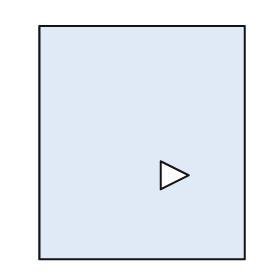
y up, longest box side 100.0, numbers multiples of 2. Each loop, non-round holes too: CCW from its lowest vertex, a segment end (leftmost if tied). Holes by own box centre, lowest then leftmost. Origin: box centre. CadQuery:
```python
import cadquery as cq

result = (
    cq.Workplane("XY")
    .moveTo(-44.0, -50.0)
    .lineTo(44.0, -50.0)
    .lineTo(44.0, 50.0)
    .lineTo(-44.0, 50.0)
    .close()
    .moveTo(8.0, -20.0)
    .lineTo(20.0, -14.0)
    .lineTo(8.0, -8.0)
    .close()
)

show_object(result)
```